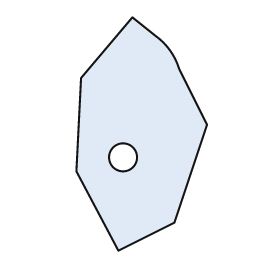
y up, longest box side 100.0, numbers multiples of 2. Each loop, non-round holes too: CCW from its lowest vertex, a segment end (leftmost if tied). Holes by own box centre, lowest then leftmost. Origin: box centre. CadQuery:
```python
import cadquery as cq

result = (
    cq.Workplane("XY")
    .moveTo(-10.0, -50.0)
    .lineTo(14.0, -38.0)
    .lineTo(28.0, 4.0)
    .lineTo(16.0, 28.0)
    .threePointArc((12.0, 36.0), (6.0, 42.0))
    .lineTo(-4.0, 50.0)
    .lineTo(-26.0, 24.0)
    .lineTo(-28.0, -16.0)
    .close()
    .moveTo(-8.0, -10.0)
    .circle(6.0)
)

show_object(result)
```